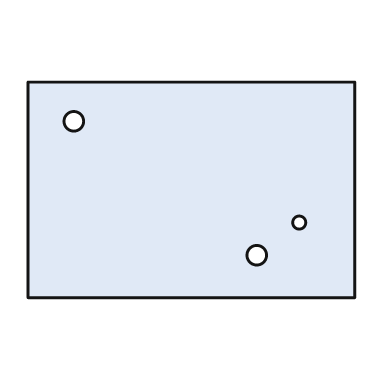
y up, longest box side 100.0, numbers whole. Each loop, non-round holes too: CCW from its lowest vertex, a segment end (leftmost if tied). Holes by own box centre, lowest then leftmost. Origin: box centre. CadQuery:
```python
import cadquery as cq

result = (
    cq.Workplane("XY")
    .moveTo(-50.0, -33.0)
    .lineTo(50.0, -33.0)
    .lineTo(50.0, 33.0)
    .lineTo(-50.0, 33.0)
    .close()
    .moveTo(20.0, -20.0)
    .circle(3.0)
    .moveTo(33.0, -10.0)
    .circle(2.0)
    .moveTo(-36.0, 21.0)
    .circle(3.0)
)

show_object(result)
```